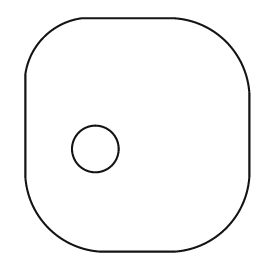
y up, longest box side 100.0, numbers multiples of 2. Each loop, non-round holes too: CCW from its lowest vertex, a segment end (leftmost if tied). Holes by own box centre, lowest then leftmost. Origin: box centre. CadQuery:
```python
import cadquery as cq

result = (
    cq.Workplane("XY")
    .moveTo(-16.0, -50.0)
    .lineTo(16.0, -50.0)
    .threePointArc((38.0, -40.0), (48.0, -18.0))
    .lineTo(48.0, 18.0)
    .threePointArc((38.0, 40.0), (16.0, 50.0))
    .lineTo(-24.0, 50.0)
    .threePointArc((-40.0, 42.0), (-48.0, 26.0))
    .lineTo(-48.0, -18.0)
    .threePointArc((-38.0, -40.0), (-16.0, -50.0))
    .close()
    .moveTo(-18.0, -6.0)
    .circle(10.0)
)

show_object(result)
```